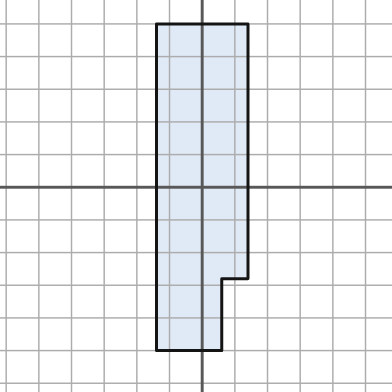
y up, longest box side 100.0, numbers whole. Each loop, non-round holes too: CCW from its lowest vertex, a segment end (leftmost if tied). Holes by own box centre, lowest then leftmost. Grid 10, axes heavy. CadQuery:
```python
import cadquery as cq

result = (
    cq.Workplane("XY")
    .moveTo(-14.0, -50.0)
    .lineTo(6.0, -50.0)
    .lineTo(6.0, -28.0)
    .lineTo(14.0, -28.0)
    .lineTo(14.0, 50.0)
    .lineTo(-14.0, 50.0)
    .close()
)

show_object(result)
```